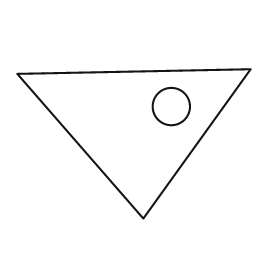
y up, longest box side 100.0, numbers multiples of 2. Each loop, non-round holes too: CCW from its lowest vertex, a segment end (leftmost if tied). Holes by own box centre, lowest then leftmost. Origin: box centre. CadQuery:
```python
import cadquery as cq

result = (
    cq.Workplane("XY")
    .moveTo(4.0, -32.0)
    .lineTo(50.0, 32.0)
    .lineTo(-50.0, 30.0)
    .close()
    .moveTo(16.0, 16.0)
    .circle(8.0)
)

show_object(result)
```